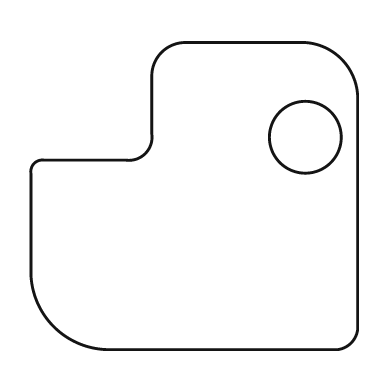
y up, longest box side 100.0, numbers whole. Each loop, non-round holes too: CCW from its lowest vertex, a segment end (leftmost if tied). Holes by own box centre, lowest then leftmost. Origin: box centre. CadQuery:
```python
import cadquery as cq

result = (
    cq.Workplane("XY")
    .moveTo(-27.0, -47.0)
    .lineTo(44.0, -47.0)
    .threePointArc((48.0, -45.0), (50.0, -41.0))
    .lineTo(50.0, 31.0)
    .threePointArc((45.0, 42.0), (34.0, 47.0))
    .lineTo(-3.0, 47.0)
    .threePointArc((-10.0, 44.0), (-13.0, 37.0))
    .lineTo(-13.0, 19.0)
    .threePointArc((-15.0, 13.0), (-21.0, 11.0))
    .lineTo(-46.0, 11.0)
    .threePointArc((-49.0, 10.0), (-50.0, 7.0))
    .lineTo(-50.0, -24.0)
    .threePointArc((-43.0, -40.0), (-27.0, -47.0))
    .close()
    .moveTo(34.0, 18.0)
    .circle(11.0)
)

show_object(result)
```